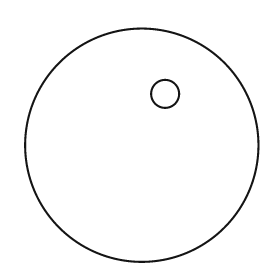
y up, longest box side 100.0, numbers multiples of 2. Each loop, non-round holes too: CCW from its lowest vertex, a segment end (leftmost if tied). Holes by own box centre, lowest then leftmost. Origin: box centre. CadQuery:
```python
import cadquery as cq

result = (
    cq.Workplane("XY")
    .moveTo(0.0, 0.0)
    .circle(50.0)
    .moveTo(10.0, 22.0)
    .circle(6.0)
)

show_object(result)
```